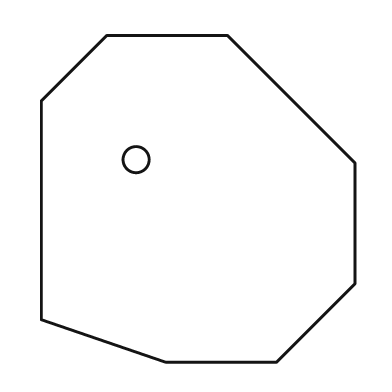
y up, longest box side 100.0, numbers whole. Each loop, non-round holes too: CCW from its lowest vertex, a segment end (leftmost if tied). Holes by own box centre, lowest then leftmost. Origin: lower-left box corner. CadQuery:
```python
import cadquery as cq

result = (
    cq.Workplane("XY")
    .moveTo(38.0, 0.0)
    .lineTo(72.0, 0.0)
    .lineTo(96.0, 24.0)
    .lineTo(96.0, 61.0)
    .lineTo(57.0, 100.0)
    .lineTo(20.0, 100.0)
    .lineTo(0.0, 80.0)
    .lineTo(0.0, 13.0)
    .close()
    .moveTo(29.0, 62.0)
    .circle(4.0)
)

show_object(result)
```